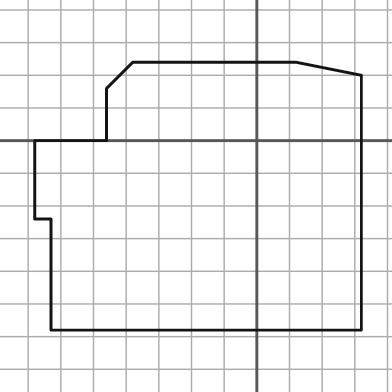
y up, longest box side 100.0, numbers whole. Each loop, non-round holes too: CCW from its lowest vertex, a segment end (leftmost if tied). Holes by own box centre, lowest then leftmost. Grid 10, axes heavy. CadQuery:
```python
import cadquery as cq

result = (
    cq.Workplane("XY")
    .moveTo(-63.0, -58.0)
    .lineTo(32.0, -58.0)
    .lineTo(32.0, 20.0)
    .lineTo(12.0, 24.0)
    .lineTo(-38.0, 24.0)
    .lineTo(-46.0, 16.0)
    .lineTo(-46.0, 0.0)
    .lineTo(-68.0, 0.0)
    .lineTo(-68.0, -24.0)
    .lineTo(-63.0, -24.0)
    .close()
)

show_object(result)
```